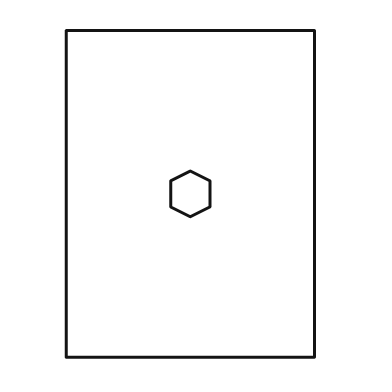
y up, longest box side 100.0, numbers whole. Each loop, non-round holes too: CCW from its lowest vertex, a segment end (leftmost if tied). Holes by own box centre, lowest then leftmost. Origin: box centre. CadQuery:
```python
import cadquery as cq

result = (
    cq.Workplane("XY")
    .moveTo(-38.0, -50.0)
    .lineTo(38.0, -50.0)
    .lineTo(38.0, 50.0)
    .lineTo(-38.0, 50.0)
    .close()
    .moveTo(0.0, -7.0)
    .lineTo(6.0, -4.0)
    .lineTo(6.0, 4.0)
    .lineTo(0.0, 7.0)
    .lineTo(-6.0, 4.0)
    .lineTo(-6.0, -4.0)
    .close()
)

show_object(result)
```